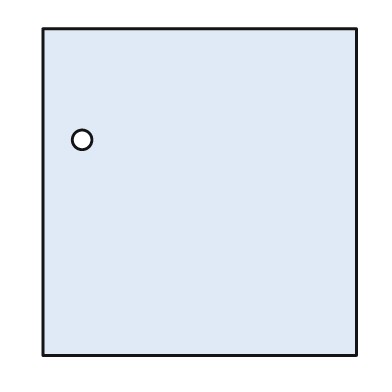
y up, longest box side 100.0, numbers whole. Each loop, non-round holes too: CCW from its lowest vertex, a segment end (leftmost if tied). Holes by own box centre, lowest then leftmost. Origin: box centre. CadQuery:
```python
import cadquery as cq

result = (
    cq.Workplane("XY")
    .moveTo(-48.0, -50.0)
    .lineTo(48.0, -50.0)
    .lineTo(48.0, 50.0)
    .lineTo(-48.0, 50.0)
    .close()
    .moveTo(-36.0, 16.0)
    .circle(3.0)
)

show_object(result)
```